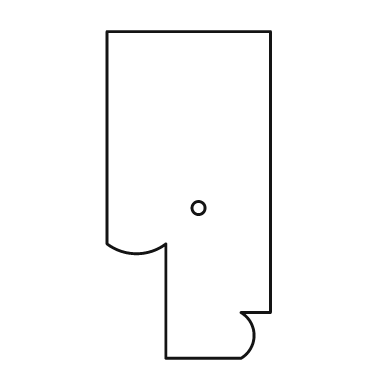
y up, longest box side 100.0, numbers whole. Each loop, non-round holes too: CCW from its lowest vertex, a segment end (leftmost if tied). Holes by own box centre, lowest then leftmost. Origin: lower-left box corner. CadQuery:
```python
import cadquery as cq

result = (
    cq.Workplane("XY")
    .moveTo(18.0, 0.0)
    .lineTo(41.0, 0.0)
    .threePointArc((45.0, 7.0), (41.0, 14.0))
    .lineTo(50.0, 14.0)
    .lineTo(50.0, 100.0)
    .lineTo(0.0, 100.0)
    .lineTo(0.0, 35.0)
    .threePointArc((9.0, 32.0), (18.0, 35.0))
    .close()
    .moveTo(28.0, 46.0)
    .circle(2.0)
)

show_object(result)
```